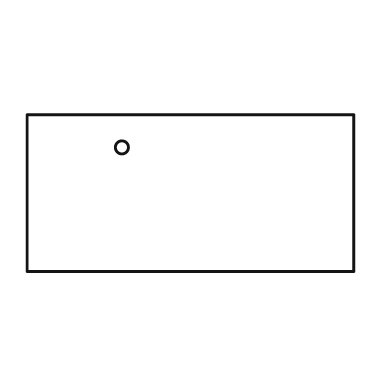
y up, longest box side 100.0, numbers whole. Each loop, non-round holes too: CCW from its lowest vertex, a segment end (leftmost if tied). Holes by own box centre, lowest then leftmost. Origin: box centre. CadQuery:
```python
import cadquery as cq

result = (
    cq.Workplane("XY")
    .moveTo(-50.0, -24.0)
    .lineTo(50.0, -24.0)
    .lineTo(50.0, 24.0)
    .lineTo(-50.0, 24.0)
    .close()
    .moveTo(-21.0, 14.0)
    .circle(2.0)
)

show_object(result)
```